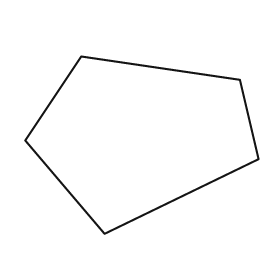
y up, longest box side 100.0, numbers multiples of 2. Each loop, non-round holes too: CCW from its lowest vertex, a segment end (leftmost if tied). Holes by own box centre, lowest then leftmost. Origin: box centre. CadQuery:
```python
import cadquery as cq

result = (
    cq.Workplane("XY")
    .moveTo(-16.0, -38.0)
    .lineTo(50.0, -6.0)
    .lineTo(42.0, 28.0)
    .lineTo(-26.0, 38.0)
    .lineTo(-50.0, 2.0)
    .close()
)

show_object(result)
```